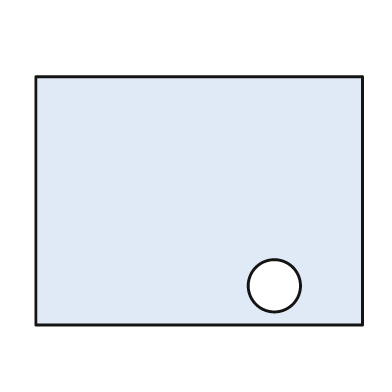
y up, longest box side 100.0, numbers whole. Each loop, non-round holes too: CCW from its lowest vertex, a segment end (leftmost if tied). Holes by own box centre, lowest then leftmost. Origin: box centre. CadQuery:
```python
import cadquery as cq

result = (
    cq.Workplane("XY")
    .moveTo(-50.0, -38.0)
    .lineTo(50.0, -38.0)
    .lineTo(50.0, 38.0)
    .lineTo(-50.0, 38.0)
    .close()
    .moveTo(23.0, -26.0)
    .circle(8.0)
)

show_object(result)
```